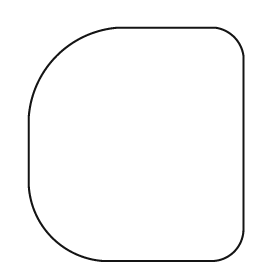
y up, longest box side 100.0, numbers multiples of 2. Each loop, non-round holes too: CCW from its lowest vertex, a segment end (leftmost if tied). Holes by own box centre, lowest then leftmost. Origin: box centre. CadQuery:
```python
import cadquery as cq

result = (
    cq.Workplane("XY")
    .moveTo(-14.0, -50.0)
    .lineTo(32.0, -50.0)
    .threePointArc((42.0, -46.0), (46.0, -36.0))
    .lineTo(46.0, 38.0)
    .threePointArc((42.0, 46.0), (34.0, 50.0))
    .lineTo(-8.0, 50.0)
    .threePointArc((-34.0, 38.0), (-46.0, 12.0))
    .lineTo(-46.0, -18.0)
    .threePointArc((-36.0, -40.0), (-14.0, -50.0))
    .close()
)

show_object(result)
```